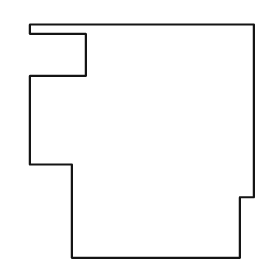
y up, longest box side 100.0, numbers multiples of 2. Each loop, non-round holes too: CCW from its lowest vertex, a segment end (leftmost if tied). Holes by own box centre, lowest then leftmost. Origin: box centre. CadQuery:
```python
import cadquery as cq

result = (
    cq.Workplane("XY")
    .moveTo(-30.0, -50.0)
    .lineTo(42.0, -50.0)
    .lineTo(42.0, -24.0)
    .lineTo(48.0, -24.0)
    .lineTo(48.0, 50.0)
    .lineTo(-48.0, 50.0)
    .lineTo(-48.0, 46.0)
    .lineTo(-24.0, 46.0)
    .lineTo(-24.0, 28.0)
    .lineTo(-48.0, 28.0)
    .lineTo(-48.0, -10.0)
    .lineTo(-30.0, -10.0)
    .close()
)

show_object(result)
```